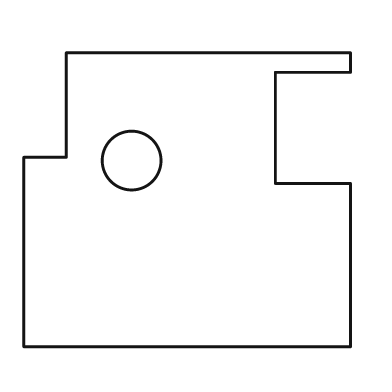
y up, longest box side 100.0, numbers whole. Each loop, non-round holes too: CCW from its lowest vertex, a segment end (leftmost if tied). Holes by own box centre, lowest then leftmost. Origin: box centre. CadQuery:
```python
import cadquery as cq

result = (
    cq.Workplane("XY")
    .moveTo(-50.0, -45.0)
    .lineTo(50.0, -45.0)
    .lineTo(50.0, 5.0)
    .lineTo(27.0, 5.0)
    .lineTo(27.0, 39.0)
    .lineTo(50.0, 39.0)
    .lineTo(50.0, 45.0)
    .lineTo(-37.0, 45.0)
    .lineTo(-37.0, 13.0)
    .lineTo(-50.0, 13.0)
    .close()
    .moveTo(-17.0, 12.0)
    .circle(9.0)
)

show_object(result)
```